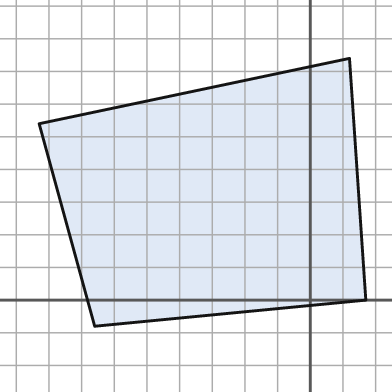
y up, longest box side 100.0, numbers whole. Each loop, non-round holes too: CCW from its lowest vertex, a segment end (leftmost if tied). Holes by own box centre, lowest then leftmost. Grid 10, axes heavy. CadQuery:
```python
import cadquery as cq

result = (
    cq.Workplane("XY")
    .moveTo(-66.0, -8.0)
    .lineTo(17.0, 0.0)
    .lineTo(12.0, 74.0)
    .lineTo(-83.0, 54.0)
    .close()
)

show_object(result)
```